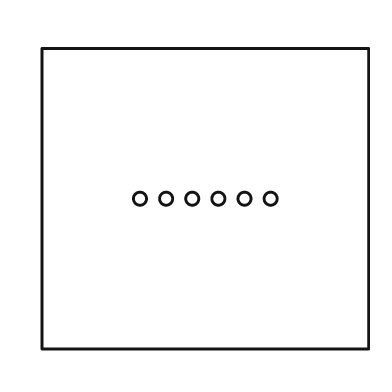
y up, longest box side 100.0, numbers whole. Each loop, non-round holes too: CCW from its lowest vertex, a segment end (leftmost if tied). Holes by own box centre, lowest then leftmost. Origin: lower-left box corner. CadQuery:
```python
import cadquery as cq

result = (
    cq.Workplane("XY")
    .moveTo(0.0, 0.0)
    .lineTo(100.0, 0.0)
    .lineTo(100.0, 92.0)
    .lineTo(0.0, 92.0)
    .close()
    .moveTo(30.0, 46.0)
    .circle(2.0)
    .moveTo(38.0, 46.0)
    .circle(2.0)
    .moveTo(46.0, 46.0)
    .circle(2.0)
    .moveTo(54.0, 46.0)
    .circle(2.0)
    .moveTo(62.0, 46.0)
    .circle(2.0)
    .moveTo(70.0, 46.0)
    .circle(2.0)
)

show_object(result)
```